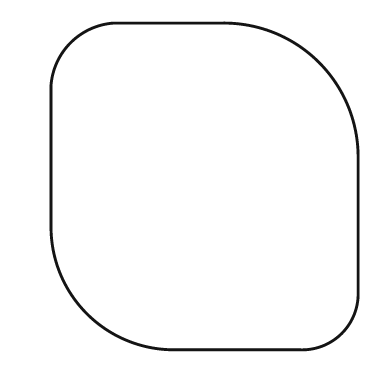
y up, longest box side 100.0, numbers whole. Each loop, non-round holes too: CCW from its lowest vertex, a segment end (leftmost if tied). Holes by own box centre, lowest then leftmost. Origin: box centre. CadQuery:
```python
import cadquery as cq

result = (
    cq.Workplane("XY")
    .moveTo(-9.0, -50.0)
    .lineTo(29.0, -50.0)
    .threePointArc((42.0, -45.0), (47.0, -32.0))
    .lineTo(47.0, 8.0)
    .threePointArc((35.0, 38.0), (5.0, 50.0))
    .lineTo(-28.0, 50.0)
    .threePointArc((-41.0, 44.0), (-47.0, 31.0))
    .lineTo(-47.0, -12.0)
    .threePointArc((-36.0, -39.0), (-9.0, -50.0))
    .close()
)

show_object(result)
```